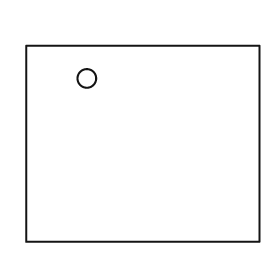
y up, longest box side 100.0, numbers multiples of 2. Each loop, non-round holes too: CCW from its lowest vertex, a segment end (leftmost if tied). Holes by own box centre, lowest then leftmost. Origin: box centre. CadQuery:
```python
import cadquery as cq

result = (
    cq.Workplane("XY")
    .moveTo(-50.0, -42.0)
    .lineTo(50.0, -42.0)
    .lineTo(50.0, 42.0)
    .lineTo(-50.0, 42.0)
    .close()
    .moveTo(-24.0, 28.0)
    .circle(4.0)
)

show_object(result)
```